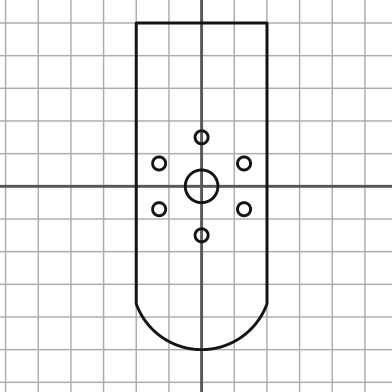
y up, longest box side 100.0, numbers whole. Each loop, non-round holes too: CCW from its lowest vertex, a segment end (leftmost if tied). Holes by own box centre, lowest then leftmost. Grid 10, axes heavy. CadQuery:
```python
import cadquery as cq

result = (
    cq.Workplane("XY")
    .moveTo(-20.0, -36.0)
    .threePointArc((0.0, -50.0), (20.0, -36.0))
    .lineTo(20.0, 50.0)
    .lineTo(-20.0, 50.0)
    .close()
    .moveTo(0.0, -15.0)
    .circle(2.0)
    .moveTo(-13.0, -7.0)
    .circle(2.0)
    .moveTo(13.0, -7.0)
    .circle(2.0)
    .moveTo(0.0, 0.0)
    .circle(5.0)
    .moveTo(-13.0, 7.0)
    .circle(2.0)
    .moveTo(13.0, 7.0)
    .circle(2.0)
    .moveTo(0.0, 15.0)
    .circle(2.0)
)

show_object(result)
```